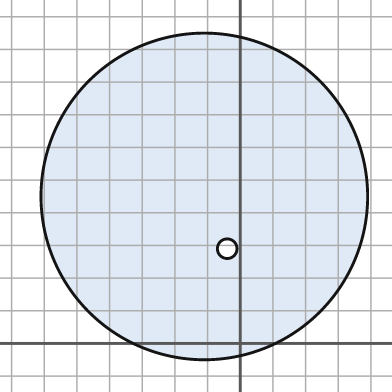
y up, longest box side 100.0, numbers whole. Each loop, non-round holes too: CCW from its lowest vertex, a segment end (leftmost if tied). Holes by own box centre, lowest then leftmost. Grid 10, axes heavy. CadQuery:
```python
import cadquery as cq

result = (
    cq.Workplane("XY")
    .moveTo(-11.0, 45.0)
    .circle(50.0)
    .moveTo(-4.0, 29.0)
    .circle(3.0)
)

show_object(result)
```